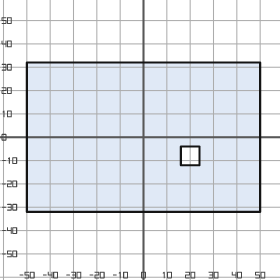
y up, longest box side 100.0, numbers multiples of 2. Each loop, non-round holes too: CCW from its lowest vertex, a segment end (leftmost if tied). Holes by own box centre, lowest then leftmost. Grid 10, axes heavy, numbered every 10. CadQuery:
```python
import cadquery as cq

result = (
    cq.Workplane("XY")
    .moveTo(-50.0, -32.0)
    .lineTo(50.0, -32.0)
    .lineTo(50.0, 32.0)
    .lineTo(-50.0, 32.0)
    .close()
    .moveTo(16.0, -12.0)
    .lineTo(24.0, -12.0)
    .lineTo(24.0, -4.0)
    .lineTo(16.0, -4.0)
    .close()
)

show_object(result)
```